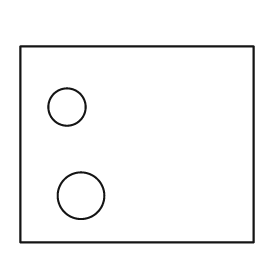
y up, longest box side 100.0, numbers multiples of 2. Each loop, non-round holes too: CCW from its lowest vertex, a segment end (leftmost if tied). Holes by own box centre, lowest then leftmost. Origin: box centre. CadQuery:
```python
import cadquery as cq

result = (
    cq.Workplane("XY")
    .moveTo(-50.0, -42.0)
    .lineTo(50.0, -42.0)
    .lineTo(50.0, 42.0)
    .lineTo(-50.0, 42.0)
    .close()
    .moveTo(-24.0, -22.0)
    .circle(10.0)
    .moveTo(-30.0, 16.0)
    .circle(8.0)
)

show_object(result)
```